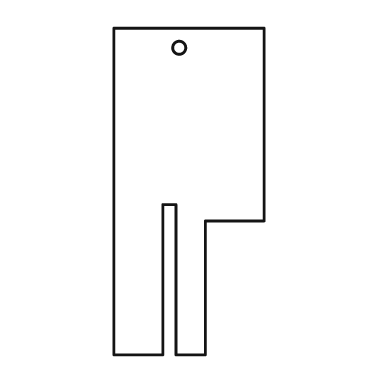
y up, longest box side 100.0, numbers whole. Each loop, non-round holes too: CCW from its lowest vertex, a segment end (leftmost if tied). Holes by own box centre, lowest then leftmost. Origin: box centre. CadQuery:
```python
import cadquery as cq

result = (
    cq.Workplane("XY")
    .moveTo(-23.0, -50.0)
    .lineTo(-8.0, -50.0)
    .lineTo(-8.0, -4.0)
    .lineTo(-4.0, -4.0)
    .lineTo(-4.0, -50.0)
    .lineTo(5.0, -50.0)
    .lineTo(5.0, -9.0)
    .lineTo(23.0, -9.0)
    .lineTo(23.0, 50.0)
    .lineTo(-23.0, 50.0)
    .close()
    .moveTo(-3.0, 44.0)
    .circle(2.0)
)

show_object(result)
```